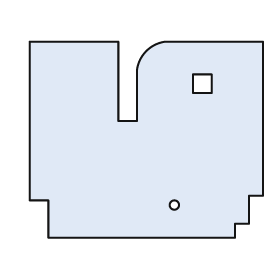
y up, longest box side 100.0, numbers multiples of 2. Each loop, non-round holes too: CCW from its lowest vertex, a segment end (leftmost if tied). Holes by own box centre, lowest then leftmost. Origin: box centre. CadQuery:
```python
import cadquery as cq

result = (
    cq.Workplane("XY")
    .moveTo(-42.0, -42.0)
    .lineTo(38.0, -42.0)
    .lineTo(38.0, -36.0)
    .lineTo(44.0, -36.0)
    .lineTo(44.0, -24.0)
    .lineTo(50.0, -24.0)
    .lineTo(50.0, 42.0)
    .lineTo(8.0, 42.0)
    .threePointArc((0.0, 38.0), (-4.0, 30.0))
    .lineTo(-4.0, 8.0)
    .lineTo(-12.0, 8.0)
    .lineTo(-12.0, 42.0)
    .lineTo(-50.0, 42.0)
    .lineTo(-50.0, -26.0)
    .lineTo(-42.0, -26.0)
    .close()
    .moveTo(12.0, -28.0)
    .circle(2.0)
    .moveTo(20.0, 20.0)
    .lineTo(28.0, 20.0)
    .lineTo(28.0, 28.0)
    .lineTo(20.0, 28.0)
    .close()
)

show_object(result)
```